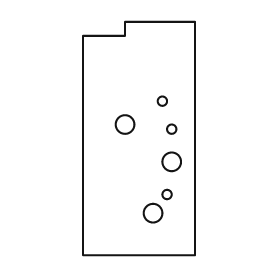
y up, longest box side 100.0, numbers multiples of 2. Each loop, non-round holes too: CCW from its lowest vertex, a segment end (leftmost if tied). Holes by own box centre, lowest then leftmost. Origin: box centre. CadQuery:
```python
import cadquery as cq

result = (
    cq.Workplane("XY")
    .moveTo(-24.0, -50.0)
    .lineTo(24.0, -50.0)
    .lineTo(24.0, 50.0)
    .lineTo(-6.0, 50.0)
    .lineTo(-6.0, 44.0)
    .lineTo(-24.0, 44.0)
    .close()
    .moveTo(6.0, -32.0)
    .circle(4.0)
    .moveTo(12.0, -24.0)
    .circle(2.0)
    .moveTo(14.0, -10.0)
    .circle(4.0)
    .moveTo(14.0, 4.0)
    .circle(2.0)
    .moveTo(-6.0, 6.0)
    .circle(4.0)
    .moveTo(10.0, 16.0)
    .circle(2.0)
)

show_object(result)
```